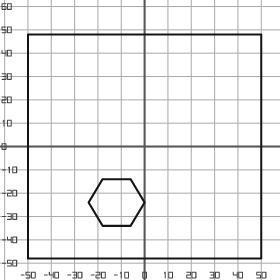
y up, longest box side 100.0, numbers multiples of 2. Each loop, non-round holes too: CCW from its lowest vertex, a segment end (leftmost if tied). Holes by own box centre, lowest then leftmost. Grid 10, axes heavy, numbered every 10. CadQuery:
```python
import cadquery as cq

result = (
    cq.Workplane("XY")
    .moveTo(-50.0, -48.0)
    .lineTo(50.0, -48.0)
    .lineTo(50.0, 48.0)
    .lineTo(-50.0, 48.0)
    .close()
    .moveTo(-18.0, -34.0)
    .lineTo(-6.0, -34.0)
    .lineTo(0.0, -24.0)
    .lineTo(-6.0, -14.0)
    .lineTo(-18.0, -14.0)
    .lineTo(-24.0, -24.0)
    .close()
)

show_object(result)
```